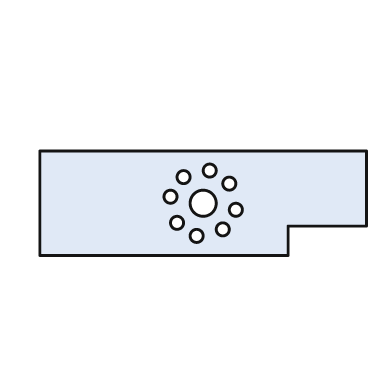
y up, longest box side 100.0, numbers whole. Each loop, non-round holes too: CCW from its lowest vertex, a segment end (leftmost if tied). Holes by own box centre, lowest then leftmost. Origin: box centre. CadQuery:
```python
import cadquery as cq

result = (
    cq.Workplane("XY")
    .moveTo(-50.0, -16.0)
    .lineTo(26.0, -16.0)
    .lineTo(26.0, -7.0)
    .lineTo(50.0, -7.0)
    .lineTo(50.0, 16.0)
    .lineTo(-50.0, 16.0)
    .close()
    .moveTo(-2.0, -10.0)
    .circle(2.0)
    .moveTo(6.0, -8.0)
    .circle(2.0)
    .moveTo(-8.0, -6.0)
    .circle(2.0)
    .moveTo(10.0, -2.0)
    .circle(2.0)
    .moveTo(0.0, 0.0)
    .circle(4.0)
    .moveTo(-10.0, 2.0)
    .circle(2.0)
    .moveTo(8.0, 6.0)
    .circle(2.0)
    .moveTo(-6.0, 8.0)
    .circle(2.0)
    .moveTo(2.0, 10.0)
    .circle(2.0)
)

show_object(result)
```